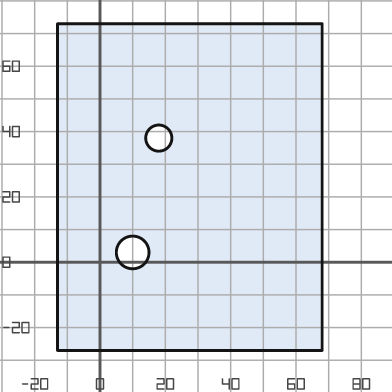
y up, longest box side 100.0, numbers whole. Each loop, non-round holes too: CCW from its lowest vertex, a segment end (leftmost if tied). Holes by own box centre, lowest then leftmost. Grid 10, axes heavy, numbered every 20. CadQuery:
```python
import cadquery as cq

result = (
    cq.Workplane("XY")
    .moveTo(-13.0, -27.0)
    .lineTo(68.0, -27.0)
    .lineTo(68.0, 73.0)
    .lineTo(-13.0, 73.0)
    .close()
    .moveTo(10.0, 3.0)
    .circle(5.0)
    .moveTo(18.0, 38.0)
    .circle(4.0)
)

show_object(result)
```